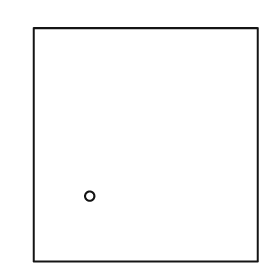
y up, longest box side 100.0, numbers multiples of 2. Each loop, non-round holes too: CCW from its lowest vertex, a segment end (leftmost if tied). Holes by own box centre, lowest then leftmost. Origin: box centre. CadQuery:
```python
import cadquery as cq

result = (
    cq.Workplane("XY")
    .moveTo(-48.0, -50.0)
    .lineTo(48.0, -50.0)
    .lineTo(48.0, 50.0)
    .lineTo(-48.0, 50.0)
    .close()
    .moveTo(-24.0, -22.0)
    .circle(2.0)
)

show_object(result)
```